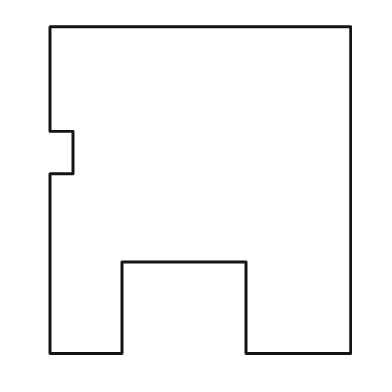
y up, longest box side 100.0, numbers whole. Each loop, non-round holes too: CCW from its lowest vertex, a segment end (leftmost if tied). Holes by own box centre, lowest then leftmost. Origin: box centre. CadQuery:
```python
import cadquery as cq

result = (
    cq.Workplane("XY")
    .moveTo(-46.0, -50.0)
    .lineTo(-24.0, -50.0)
    .lineTo(-24.0, -22.0)
    .lineTo(14.0, -22.0)
    .lineTo(14.0, -50.0)
    .lineTo(46.0, -50.0)
    .lineTo(46.0, 50.0)
    .lineTo(-46.0, 50.0)
    .lineTo(-46.0, 18.0)
    .lineTo(-39.0, 18.0)
    .lineTo(-39.0, 5.0)
    .lineTo(-46.0, 5.0)
    .close()
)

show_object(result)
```